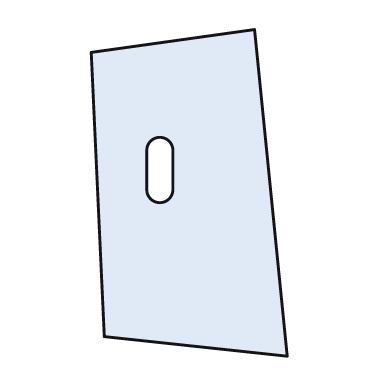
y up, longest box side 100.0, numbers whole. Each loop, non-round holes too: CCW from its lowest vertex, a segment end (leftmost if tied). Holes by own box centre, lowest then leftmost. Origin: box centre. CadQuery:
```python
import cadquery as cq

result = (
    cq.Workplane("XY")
    .moveTo(30.0, -50.0)
    .lineTo(20.0, 50.0)
    .lineTo(-30.0, 43.0)
    .lineTo(-26.0, -44.0)
    .close()
    .moveTo(-13.0, 1.0)
    .threePointArc((-9.0, -3.0), (-5.0, 1.0))
    .lineTo(-5.0, 13.0)
    .threePointArc((-9.0, 17.0), (-13.0, 13.0))
    .close()
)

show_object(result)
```